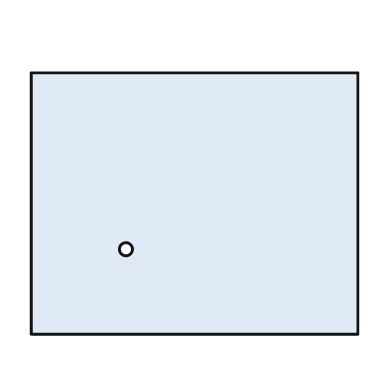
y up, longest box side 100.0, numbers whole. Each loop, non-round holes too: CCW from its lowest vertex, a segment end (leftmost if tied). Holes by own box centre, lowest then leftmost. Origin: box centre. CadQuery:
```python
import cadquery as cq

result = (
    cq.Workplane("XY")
    .moveTo(-50.0, -40.0)
    .lineTo(50.0, -40.0)
    .lineTo(50.0, 40.0)
    .lineTo(-50.0, 40.0)
    .close()
    .moveTo(-21.0, -14.0)
    .circle(2.0)
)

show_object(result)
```